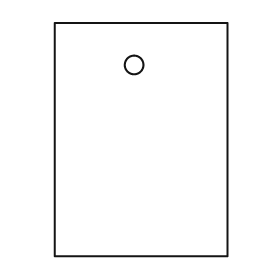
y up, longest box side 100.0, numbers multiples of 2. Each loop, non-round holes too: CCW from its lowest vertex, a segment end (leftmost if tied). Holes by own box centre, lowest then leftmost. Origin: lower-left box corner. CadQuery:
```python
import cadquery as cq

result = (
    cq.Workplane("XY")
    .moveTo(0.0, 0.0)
    .lineTo(74.0, 0.0)
    .lineTo(74.0, 100.0)
    .lineTo(0.0, 100.0)
    .close()
    .moveTo(34.0, 82.0)
    .circle(4.0)
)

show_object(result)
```